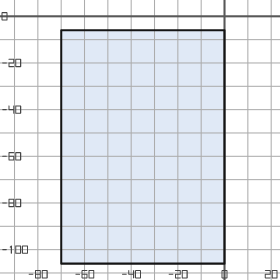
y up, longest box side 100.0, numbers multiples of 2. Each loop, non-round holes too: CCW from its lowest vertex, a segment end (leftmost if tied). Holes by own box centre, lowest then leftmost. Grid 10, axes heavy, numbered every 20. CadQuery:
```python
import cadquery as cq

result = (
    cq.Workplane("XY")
    .moveTo(-70.0, -106.0)
    .lineTo(0.0, -106.0)
    .lineTo(0.0, -6.0)
    .lineTo(-70.0, -6.0)
    .close()
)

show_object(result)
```